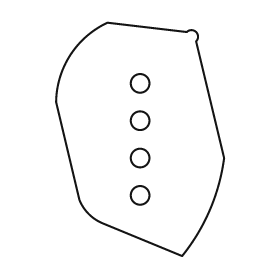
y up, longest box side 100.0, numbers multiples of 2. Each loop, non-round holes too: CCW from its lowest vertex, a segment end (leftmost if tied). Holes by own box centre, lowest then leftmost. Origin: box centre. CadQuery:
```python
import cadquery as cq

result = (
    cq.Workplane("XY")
    .moveTo(18.0, -50.0)
    .threePointArc((30.0, -30.0), (36.0, -8.0))
    .lineTo(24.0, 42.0)
    .threePointArc((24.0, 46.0), (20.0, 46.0))
    .lineTo(-14.0, 50.0)
    .threePointArc((-30.0, 36.0), (-36.0, 16.0))
    .lineTo(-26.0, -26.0)
    .threePointArc((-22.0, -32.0), (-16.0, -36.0))
    .close()
    .moveTo(0.0, -24.0)
    .circle(4.0)
    .moveTo(0.0, -8.0)
    .circle(4.0)
    .moveTo(0.0, 8.0)
    .circle(4.0)
    .moveTo(0.0, 24.0)
    .circle(4.0)
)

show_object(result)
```